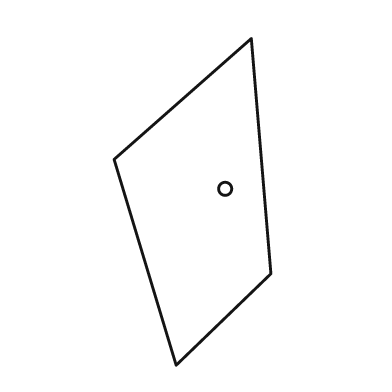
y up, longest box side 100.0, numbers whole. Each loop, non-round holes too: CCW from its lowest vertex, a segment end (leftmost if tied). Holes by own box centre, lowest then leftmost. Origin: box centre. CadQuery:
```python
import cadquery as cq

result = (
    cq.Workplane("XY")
    .moveTo(-5.0, -50.0)
    .lineTo(24.0, -22.0)
    .lineTo(18.0, 50.0)
    .lineTo(-24.0, 13.0)
    .close()
    .moveTo(10.0, 4.0)
    .circle(2.0)
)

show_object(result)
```